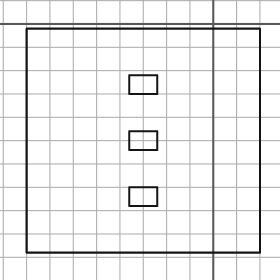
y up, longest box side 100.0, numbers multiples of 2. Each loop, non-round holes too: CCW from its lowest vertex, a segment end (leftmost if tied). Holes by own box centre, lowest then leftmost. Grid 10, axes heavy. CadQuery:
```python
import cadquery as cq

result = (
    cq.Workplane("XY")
    .moveTo(-80.0, -98.0)
    .lineTo(20.0, -98.0)
    .lineTo(20.0, -2.0)
    .lineTo(-80.0, -2.0)
    .close()
    .moveTo(-36.0, -78.0)
    .lineTo(-24.0, -78.0)
    .lineTo(-24.0, -70.0)
    .lineTo(-36.0, -70.0)
    .close()
    .moveTo(-36.0, -54.0)
    .lineTo(-24.0, -54.0)
    .lineTo(-24.0, -46.0)
    .lineTo(-36.0, -46.0)
    .close()
    .moveTo(-36.0, -30.0)
    .lineTo(-24.0, -30.0)
    .lineTo(-24.0, -22.0)
    .lineTo(-36.0, -22.0)
    .close()
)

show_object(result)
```